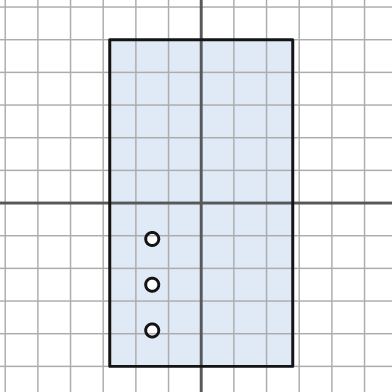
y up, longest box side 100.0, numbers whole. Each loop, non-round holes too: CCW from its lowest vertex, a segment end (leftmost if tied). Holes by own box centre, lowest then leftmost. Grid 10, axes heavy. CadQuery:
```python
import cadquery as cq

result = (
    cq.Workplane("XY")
    .moveTo(-28.0, -50.0)
    .lineTo(28.0, -50.0)
    .lineTo(28.0, 50.0)
    .lineTo(-28.0, 50.0)
    .close()
    .moveTo(-15.0, -39.0)
    .circle(2.0)
    .moveTo(-15.0, -25.0)
    .circle(2.0)
    .moveTo(-15.0, -11.0)
    .circle(2.0)
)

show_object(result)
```